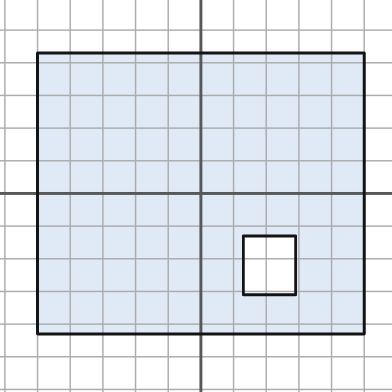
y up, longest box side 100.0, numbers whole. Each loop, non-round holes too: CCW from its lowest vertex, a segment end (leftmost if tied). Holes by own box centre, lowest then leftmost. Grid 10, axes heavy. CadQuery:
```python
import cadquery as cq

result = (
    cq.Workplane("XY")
    .moveTo(-50.0, -43.0)
    .lineTo(50.0, -43.0)
    .lineTo(50.0, 43.0)
    .lineTo(-50.0, 43.0)
    .close()
    .moveTo(13.0, -31.0)
    .lineTo(29.0, -31.0)
    .lineTo(29.0, -13.0)
    .lineTo(13.0, -13.0)
    .close()
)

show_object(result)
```